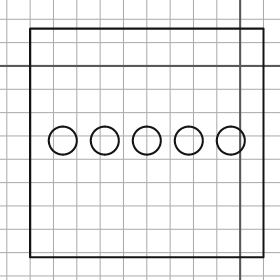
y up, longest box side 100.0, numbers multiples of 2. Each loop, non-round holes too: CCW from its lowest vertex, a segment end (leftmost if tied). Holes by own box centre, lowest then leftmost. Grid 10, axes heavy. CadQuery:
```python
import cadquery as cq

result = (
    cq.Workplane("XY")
    .moveTo(-90.0, -82.0)
    .lineTo(10.0, -82.0)
    .lineTo(10.0, 16.0)
    .lineTo(-90.0, 16.0)
    .close()
    .moveTo(-76.0, -32.0)
    .circle(6.0)
    .moveTo(-58.0, -32.0)
    .circle(6.0)
    .moveTo(-40.0, -32.0)
    .circle(6.0)
    .moveTo(-22.0, -32.0)
    .circle(6.0)
    .moveTo(-4.0, -32.0)
    .circle(6.0)
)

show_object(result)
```